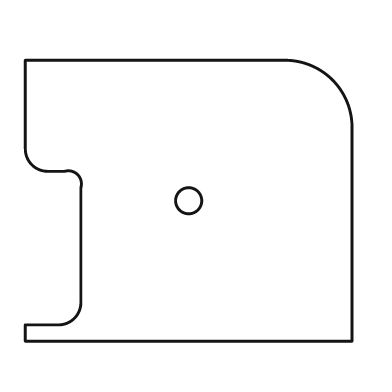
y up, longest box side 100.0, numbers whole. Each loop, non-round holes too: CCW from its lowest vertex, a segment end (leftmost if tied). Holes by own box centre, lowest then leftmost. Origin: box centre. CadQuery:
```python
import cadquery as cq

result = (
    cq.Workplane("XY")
    .moveTo(-50.0, -43.0)
    .lineTo(50.0, -43.0)
    .lineTo(50.0, 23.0)
    .threePointArc((44.0, 37.0), (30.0, 43.0))
    .lineTo(-50.0, 43.0)
    .lineTo(-50.0, 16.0)
    .threePointArc((-48.0, 11.0), (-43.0, 9.0))
    .lineTo(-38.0, 9.0)
    .threePointArc((-34.0, 8.0), (-33.0, 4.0))
    .lineTo(-33.0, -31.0)
    .threePointArc((-35.0, -36.0), (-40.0, -38.0))
    .lineTo(-50.0, -38.0)
    .close()
    .moveTo(0.0, 0.0)
    .circle(4.0)
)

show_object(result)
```